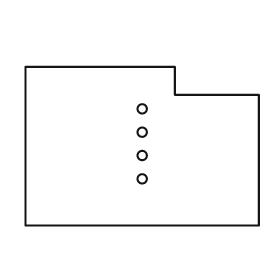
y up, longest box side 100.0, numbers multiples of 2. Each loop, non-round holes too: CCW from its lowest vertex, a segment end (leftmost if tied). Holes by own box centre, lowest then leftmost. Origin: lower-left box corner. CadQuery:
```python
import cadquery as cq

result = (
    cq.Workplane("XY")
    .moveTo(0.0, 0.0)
    .lineTo(100.0, 0.0)
    .lineTo(100.0, 56.0)
    .lineTo(64.0, 56.0)
    .lineTo(64.0, 68.0)
    .lineTo(0.0, 68.0)
    .close()
    .moveTo(50.0, 20.0)
    .circle(2.0)
    .moveTo(50.0, 30.0)
    .circle(2.0)
    .moveTo(50.0, 40.0)
    .circle(2.0)
    .moveTo(50.0, 50.0)
    .circle(2.0)
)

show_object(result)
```